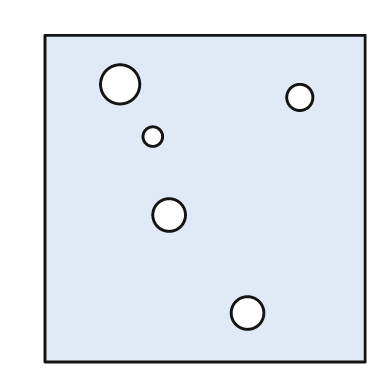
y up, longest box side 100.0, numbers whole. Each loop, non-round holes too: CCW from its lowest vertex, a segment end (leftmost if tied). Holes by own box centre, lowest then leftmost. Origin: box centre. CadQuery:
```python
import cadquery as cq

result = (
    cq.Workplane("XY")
    .moveTo(-49.0, -50.0)
    .lineTo(49.0, -50.0)
    .lineTo(49.0, 50.0)
    .lineTo(-49.0, 50.0)
    .close()
    .moveTo(13.0, -35.0)
    .circle(5.0)
    .moveTo(-11.0, -5.0)
    .circle(5.0)
    .moveTo(-16.0, 19.0)
    .circle(3.0)
    .moveTo(29.0, 31.0)
    .circle(4.0)
    .moveTo(-26.0, 35.0)
    .circle(6.0)
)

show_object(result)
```